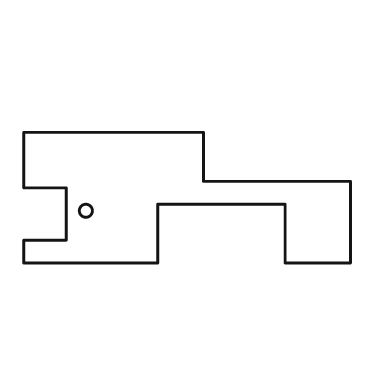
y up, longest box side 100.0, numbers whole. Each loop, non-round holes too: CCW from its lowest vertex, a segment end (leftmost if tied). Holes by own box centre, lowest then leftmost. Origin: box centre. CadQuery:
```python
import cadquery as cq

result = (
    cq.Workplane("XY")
    .moveTo(-50.0, -20.0)
    .lineTo(-9.0, -20.0)
    .lineTo(-9.0, -2.0)
    .lineTo(30.0, -2.0)
    .lineTo(30.0, -20.0)
    .lineTo(50.0, -20.0)
    .lineTo(50.0, 5.0)
    .lineTo(5.0, 5.0)
    .lineTo(5.0, 20.0)
    .lineTo(-50.0, 20.0)
    .lineTo(-50.0, 3.0)
    .lineTo(-37.0, 3.0)
    .lineTo(-37.0, -13.0)
    .lineTo(-50.0, -13.0)
    .close()
    .moveTo(-31.0, -4.0)
    .circle(2.0)
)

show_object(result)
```